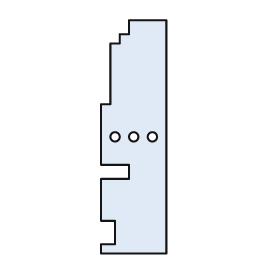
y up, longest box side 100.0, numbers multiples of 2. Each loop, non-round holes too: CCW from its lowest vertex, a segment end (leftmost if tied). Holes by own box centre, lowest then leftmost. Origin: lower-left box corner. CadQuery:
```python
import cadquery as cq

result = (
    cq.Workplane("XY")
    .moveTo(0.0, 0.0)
    .lineTo(28.0, 0.0)
    .lineTo(28.0, 100.0)
    .lineTo(12.0, 100.0)
    .lineTo(12.0, 94.0)
    .lineTo(8.0, 94.0)
    .lineTo(8.0, 90.0)
    .lineTo(4.0, 90.0)
    .lineTo(4.0, 64.0)
    .lineTo(0.0, 64.0)
    .lineTo(0.0, 38.0)
    .lineTo(12.0, 38.0)
    .lineTo(12.0, 32.0)
    .lineTo(0.0, 32.0)
    .lineTo(0.0, 14.0)
    .lineTo(6.0, 14.0)
    .lineTo(6.0, 4.0)
    .lineTo(0.0, 4.0)
    .close()
    .moveTo(6.0, 50.0)
    .circle(2.0)
    .moveTo(14.0, 50.0)
    .circle(2.0)
    .moveTo(22.0, 50.0)
    .circle(2.0)
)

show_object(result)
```